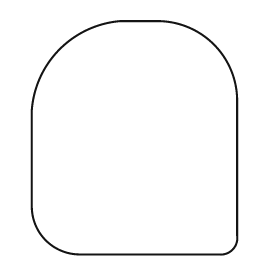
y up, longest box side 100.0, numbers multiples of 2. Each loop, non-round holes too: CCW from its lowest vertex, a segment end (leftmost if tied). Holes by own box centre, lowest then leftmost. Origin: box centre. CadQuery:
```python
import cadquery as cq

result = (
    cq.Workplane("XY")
    .moveTo(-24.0, -50.0)
    .lineTo(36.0, -50.0)
    .threePointArc((42.0, -48.0), (44.0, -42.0))
    .lineTo(44.0, 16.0)
    .threePointArc((34.0, 40.0), (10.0, 50.0))
    .lineTo(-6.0, 50.0)
    .threePointArc((-32.0, 38.0), (-44.0, 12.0))
    .lineTo(-44.0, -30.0)
    .threePointArc((-38.0, -44.0), (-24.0, -50.0))
    .close()
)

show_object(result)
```